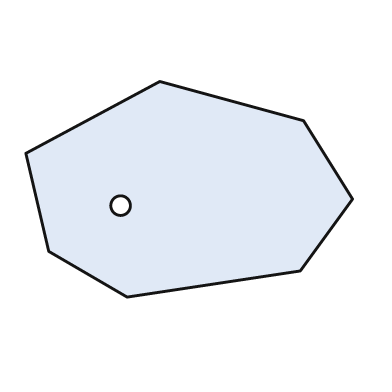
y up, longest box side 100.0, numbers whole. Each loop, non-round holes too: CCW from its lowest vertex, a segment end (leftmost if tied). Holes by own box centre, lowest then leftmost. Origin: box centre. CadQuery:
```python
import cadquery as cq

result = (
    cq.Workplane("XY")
    .moveTo(-19.0, -33.0)
    .lineTo(34.0, -25.0)
    .lineTo(50.0, -3.0)
    .lineTo(35.0, 21.0)
    .lineTo(-9.0, 33.0)
    .lineTo(-50.0, 11.0)
    .lineTo(-43.0, -19.0)
    .close()
    .moveTo(-21.0, -5.0)
    .circle(3.0)
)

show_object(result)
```